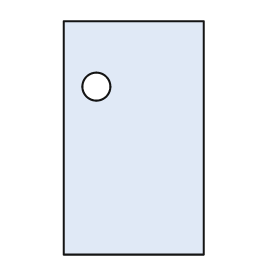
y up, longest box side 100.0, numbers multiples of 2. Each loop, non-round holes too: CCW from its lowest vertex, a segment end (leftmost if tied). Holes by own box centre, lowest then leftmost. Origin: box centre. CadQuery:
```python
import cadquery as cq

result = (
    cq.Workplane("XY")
    .moveTo(-30.0, -50.0)
    .lineTo(30.0, -50.0)
    .lineTo(30.0, 50.0)
    .lineTo(-30.0, 50.0)
    .close()
    .moveTo(-16.0, 22.0)
    .circle(6.0)
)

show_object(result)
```